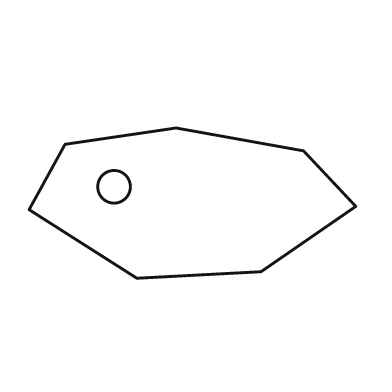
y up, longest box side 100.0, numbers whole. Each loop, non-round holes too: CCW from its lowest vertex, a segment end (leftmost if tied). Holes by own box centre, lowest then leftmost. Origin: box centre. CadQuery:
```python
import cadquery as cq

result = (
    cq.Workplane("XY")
    .moveTo(-17.0, -23.0)
    .lineTo(21.0, -21.0)
    .lineTo(50.0, -1.0)
    .lineTo(34.0, 16.0)
    .lineTo(-5.0, 23.0)
    .lineTo(-39.0, 18.0)
    .lineTo(-50.0, -2.0)
    .close()
    .moveTo(-24.0, 5.0)
    .circle(5.0)
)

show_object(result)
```